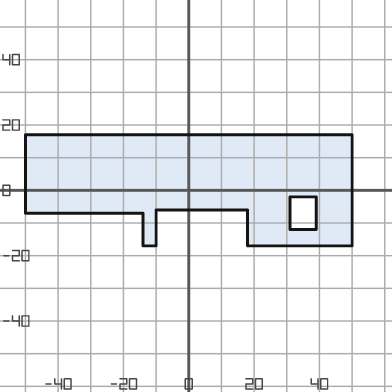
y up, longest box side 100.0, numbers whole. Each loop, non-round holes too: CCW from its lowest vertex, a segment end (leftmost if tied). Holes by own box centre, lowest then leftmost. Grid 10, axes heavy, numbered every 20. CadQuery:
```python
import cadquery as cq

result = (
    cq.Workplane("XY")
    .moveTo(-14.0, -17.0)
    .lineTo(-10.0, -17.0)
    .lineTo(-10.0, -6.0)
    .lineTo(18.0, -6.0)
    .lineTo(18.0, -17.0)
    .lineTo(50.0, -17.0)
    .lineTo(50.0, 17.0)
    .lineTo(-50.0, 17.0)
    .lineTo(-50.0, -7.0)
    .lineTo(-14.0, -7.0)
    .close()
    .moveTo(31.0, -12.0)
    .lineTo(39.0, -12.0)
    .lineTo(39.0, -2.0)
    .lineTo(31.0, -2.0)
    .close()
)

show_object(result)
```